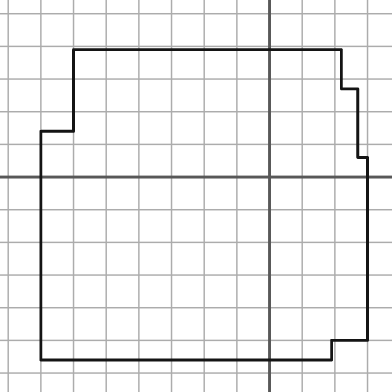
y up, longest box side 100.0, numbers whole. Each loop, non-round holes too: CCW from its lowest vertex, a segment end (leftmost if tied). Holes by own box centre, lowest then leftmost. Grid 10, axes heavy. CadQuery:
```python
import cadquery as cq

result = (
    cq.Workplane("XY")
    .moveTo(-70.0, -56.0)
    .lineTo(19.0, -56.0)
    .lineTo(19.0, -50.0)
    .lineTo(30.0, -50.0)
    .lineTo(30.0, 6.0)
    .lineTo(27.0, 6.0)
    .lineTo(27.0, 27.0)
    .lineTo(22.0, 27.0)
    .lineTo(22.0, 39.0)
    .lineTo(-60.0, 39.0)
    .lineTo(-60.0, 14.0)
    .lineTo(-70.0, 14.0)
    .close()
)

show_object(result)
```